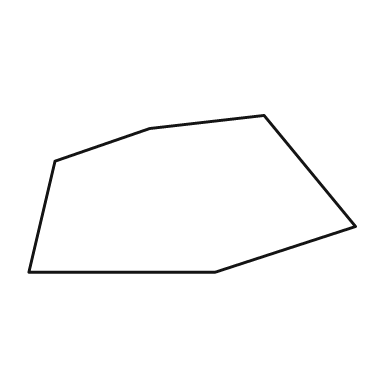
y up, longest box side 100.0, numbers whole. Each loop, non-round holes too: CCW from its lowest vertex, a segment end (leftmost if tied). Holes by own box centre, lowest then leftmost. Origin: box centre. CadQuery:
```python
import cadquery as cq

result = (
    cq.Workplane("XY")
    .moveTo(-50.0, -24.0)
    .lineTo(7.0, -24.0)
    .lineTo(50.0, -10.0)
    .lineTo(22.0, 24.0)
    .lineTo(-13.0, 20.0)
    .lineTo(-42.0, 10.0)
    .close()
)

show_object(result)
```